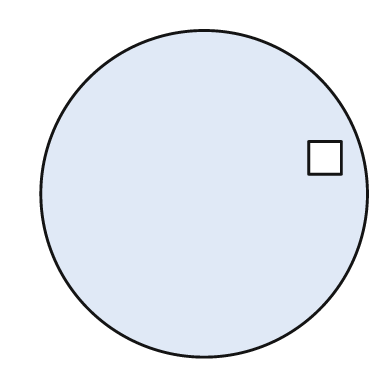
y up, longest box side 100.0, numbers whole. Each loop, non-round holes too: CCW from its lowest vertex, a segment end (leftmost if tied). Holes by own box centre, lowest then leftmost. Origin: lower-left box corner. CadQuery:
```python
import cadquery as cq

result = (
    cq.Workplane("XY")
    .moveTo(50.0, 50.0)
    .circle(50.0)
    .moveTo(82.0, 56.0)
    .lineTo(92.0, 56.0)
    .lineTo(92.0, 66.0)
    .lineTo(82.0, 66.0)
    .close()
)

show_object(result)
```